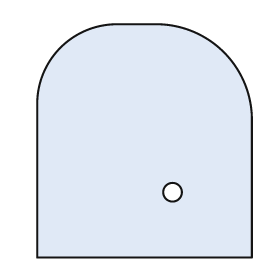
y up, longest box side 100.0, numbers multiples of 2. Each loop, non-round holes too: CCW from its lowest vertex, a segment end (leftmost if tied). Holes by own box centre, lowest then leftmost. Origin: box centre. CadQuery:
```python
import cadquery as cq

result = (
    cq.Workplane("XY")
    .moveTo(-46.0, -50.0)
    .lineTo(46.0, -50.0)
    .lineTo(46.0, 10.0)
    .threePointArc((34.0, 38.0), (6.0, 50.0))
    .lineTo(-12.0, 50.0)
    .threePointArc((-36.0, 40.0), (-46.0, 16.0))
    .close()
    .moveTo(12.0, -22.0)
    .circle(4.0)
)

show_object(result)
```